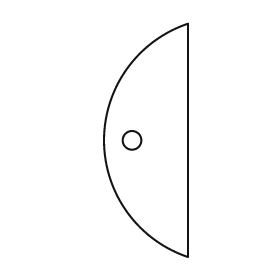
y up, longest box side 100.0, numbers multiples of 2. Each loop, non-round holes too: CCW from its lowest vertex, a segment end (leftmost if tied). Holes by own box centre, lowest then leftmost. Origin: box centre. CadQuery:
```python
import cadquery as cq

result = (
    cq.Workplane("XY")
    .moveTo(18.0, -50.0)
    .lineTo(18.0, 50.0)
    .threePointArc((-18.0, 0.0), (18.0, -50.0))
    .close()
    .moveTo(-6.0, 0.0)
    .circle(4.0)
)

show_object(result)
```